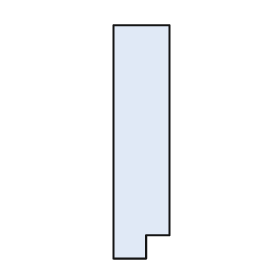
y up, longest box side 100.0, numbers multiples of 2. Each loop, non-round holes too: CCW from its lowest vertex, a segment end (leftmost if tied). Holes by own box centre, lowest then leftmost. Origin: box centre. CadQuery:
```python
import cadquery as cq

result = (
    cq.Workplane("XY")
    .moveTo(-12.0, -50.0)
    .lineTo(2.0, -50.0)
    .lineTo(2.0, -40.0)
    .lineTo(12.0, -40.0)
    .lineTo(12.0, 50.0)
    .lineTo(-12.0, 50.0)
    .close()
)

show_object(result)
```